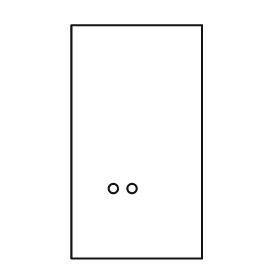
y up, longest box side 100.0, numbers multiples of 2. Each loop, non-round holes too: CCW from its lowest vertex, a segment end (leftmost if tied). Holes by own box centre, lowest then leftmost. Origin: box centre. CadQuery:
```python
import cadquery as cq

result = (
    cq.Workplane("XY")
    .moveTo(-28.0, -50.0)
    .lineTo(28.0, -50.0)
    .lineTo(28.0, 50.0)
    .lineTo(-28.0, 50.0)
    .close()
    .moveTo(-10.0, -20.0)
    .circle(2.0)
    .moveTo(-2.0, -20.0)
    .circle(2.0)
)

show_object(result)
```